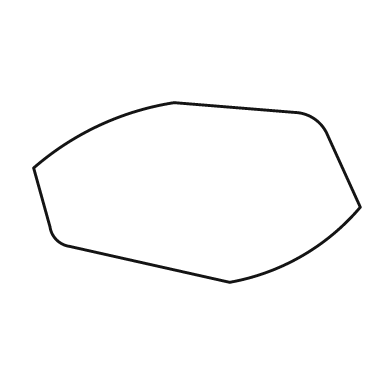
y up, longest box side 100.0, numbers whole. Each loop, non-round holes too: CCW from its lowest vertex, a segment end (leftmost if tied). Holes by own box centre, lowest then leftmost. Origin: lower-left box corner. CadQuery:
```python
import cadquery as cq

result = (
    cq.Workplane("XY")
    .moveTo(60.0, 0.0)
    .threePointArc((82.0, 8.0), (100.0, 23.0))
    .lineTo(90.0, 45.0)
    .threePointArc((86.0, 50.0), (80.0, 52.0))
    .lineTo(43.0, 55.0)
    .threePointArc((20.0, 48.0), (0.0, 35.0))
    .lineTo(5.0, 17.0)
    .threePointArc((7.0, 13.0), (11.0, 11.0))
    .close()
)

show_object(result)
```